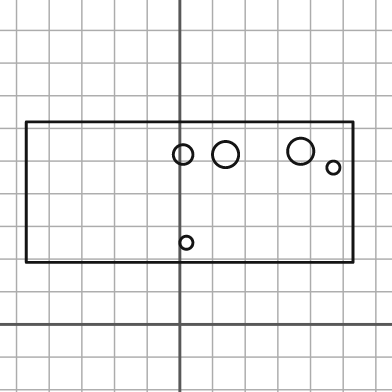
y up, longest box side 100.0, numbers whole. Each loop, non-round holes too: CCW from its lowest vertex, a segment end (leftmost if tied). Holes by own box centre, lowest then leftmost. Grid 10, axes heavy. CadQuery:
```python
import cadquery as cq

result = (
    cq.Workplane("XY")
    .moveTo(-47.0, 19.0)
    .lineTo(53.0, 19.0)
    .lineTo(53.0, 62.0)
    .lineTo(-47.0, 62.0)
    .close()
    .moveTo(2.0, 25.0)
    .circle(2.0)
    .moveTo(47.0, 48.0)
    .circle(2.0)
    .moveTo(1.0, 52.0)
    .circle(3.0)
    .moveTo(14.0, 52.0)
    .circle(4.0)
    .moveTo(37.0, 53.0)
    .circle(4.0)
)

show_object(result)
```